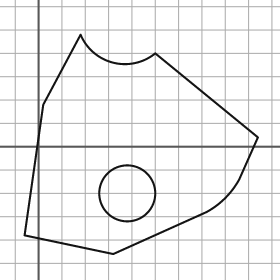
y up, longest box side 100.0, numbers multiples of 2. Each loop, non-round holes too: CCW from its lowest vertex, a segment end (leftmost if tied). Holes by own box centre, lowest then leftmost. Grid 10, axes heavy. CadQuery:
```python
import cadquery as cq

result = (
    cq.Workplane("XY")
    .moveTo(32.0, -46.0)
    .lineTo(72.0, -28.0)
    .threePointArc((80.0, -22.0), (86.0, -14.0))
    .lineTo(94.0, 4.0)
    .lineTo(50.0, 40.0)
    .threePointArc((32.0, 36.0), (18.0, 48.0))
    .lineTo(2.0, 18.0)
    .lineTo(-6.0, -38.0)
    .close()
    .moveTo(38.0, -20.0)
    .circle(12.0)
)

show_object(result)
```